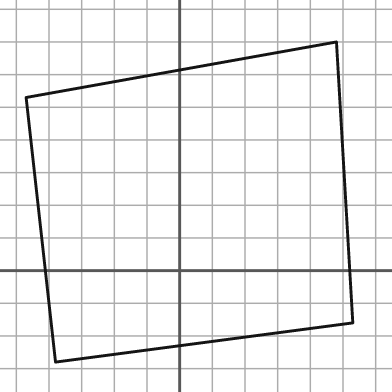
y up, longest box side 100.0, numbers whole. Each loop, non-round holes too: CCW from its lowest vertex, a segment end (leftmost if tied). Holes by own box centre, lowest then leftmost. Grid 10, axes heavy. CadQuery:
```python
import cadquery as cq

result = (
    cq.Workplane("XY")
    .moveTo(-38.0, -28.0)
    .lineTo(53.0, -16.0)
    .lineTo(48.0, 70.0)
    .lineTo(-47.0, 53.0)
    .close()
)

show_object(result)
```